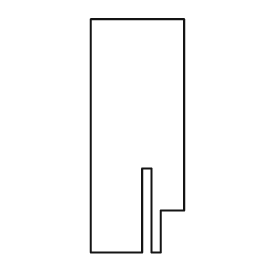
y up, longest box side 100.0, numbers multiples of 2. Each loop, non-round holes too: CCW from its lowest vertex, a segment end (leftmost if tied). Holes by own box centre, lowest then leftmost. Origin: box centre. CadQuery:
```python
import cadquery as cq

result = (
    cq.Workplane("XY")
    .moveTo(-20.0, -50.0)
    .lineTo(2.0, -50.0)
    .lineTo(2.0, -14.0)
    .lineTo(6.0, -14.0)
    .lineTo(6.0, -50.0)
    .lineTo(10.0, -50.0)
    .lineTo(10.0, -32.0)
    .lineTo(20.0, -32.0)
    .lineTo(20.0, 50.0)
    .lineTo(-20.0, 50.0)
    .close()
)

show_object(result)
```